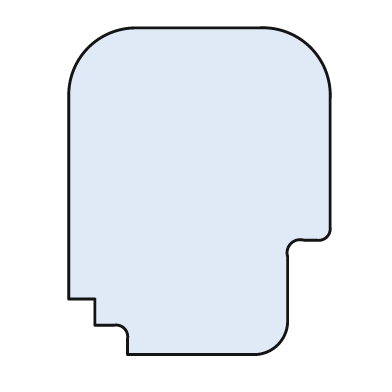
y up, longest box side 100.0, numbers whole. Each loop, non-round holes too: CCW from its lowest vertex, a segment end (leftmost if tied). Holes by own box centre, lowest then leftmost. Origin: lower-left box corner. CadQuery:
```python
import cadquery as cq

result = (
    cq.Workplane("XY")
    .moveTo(18.0, 0.0)
    .lineTo(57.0, 0.0)
    .threePointArc((64.0, 3.0), (67.0, 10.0))
    .lineTo(67.0, 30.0)
    .threePointArc((68.0, 34.0), (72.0, 35.0))
    .lineTo(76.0, 35.0)
    .threePointArc((79.0, 36.0), (80.0, 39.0))
    .lineTo(80.0, 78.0)
    .threePointArc((74.0, 94.0), (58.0, 100.0))
    .lineTo(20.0, 100.0)
    .threePointArc((6.0, 94.0), (0.0, 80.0))
    .lineTo(0.0, 17.0)
    .lineTo(8.0, 17.0)
    .lineTo(8.0, 9.0)
    .lineTo(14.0, 9.0)
    .threePointArc((17.0, 8.0), (18.0, 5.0))
    .close()
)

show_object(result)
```